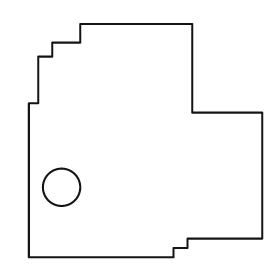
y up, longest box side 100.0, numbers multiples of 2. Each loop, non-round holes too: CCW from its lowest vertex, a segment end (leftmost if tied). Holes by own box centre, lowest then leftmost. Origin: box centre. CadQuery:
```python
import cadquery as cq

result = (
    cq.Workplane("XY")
    .moveTo(-50.0, -50.0)
    .lineTo(12.0, -50.0)
    .lineTo(12.0, -46.0)
    .lineTo(18.0, -46.0)
    .lineTo(18.0, -42.0)
    .lineTo(50.0, -42.0)
    .lineTo(50.0, 12.0)
    .lineTo(20.0, 12.0)
    .lineTo(20.0, 50.0)
    .lineTo(-28.0, 50.0)
    .lineTo(-28.0, 42.0)
    .lineTo(-40.0, 42.0)
    .lineTo(-40.0, 36.0)
    .lineTo(-46.0, 36.0)
    .lineTo(-46.0, 16.0)
    .lineTo(-50.0, 16.0)
    .close()
    .moveTo(-36.0, -20.0)
    .circle(8.0)
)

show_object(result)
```